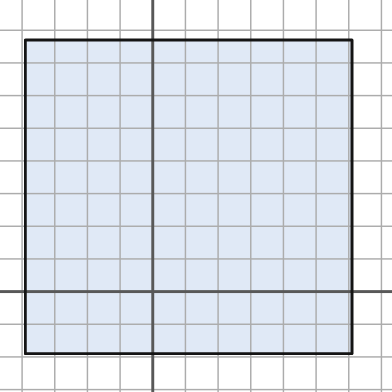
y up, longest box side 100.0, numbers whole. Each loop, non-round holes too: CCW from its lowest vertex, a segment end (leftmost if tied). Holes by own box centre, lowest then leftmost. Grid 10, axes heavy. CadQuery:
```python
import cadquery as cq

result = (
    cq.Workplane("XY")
    .moveTo(-39.0, -19.0)
    .lineTo(61.0, -19.0)
    .lineTo(61.0, 77.0)
    .lineTo(-39.0, 77.0)
    .close()
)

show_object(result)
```